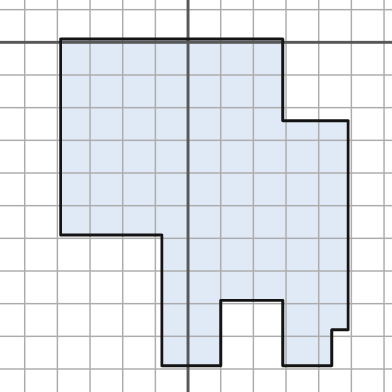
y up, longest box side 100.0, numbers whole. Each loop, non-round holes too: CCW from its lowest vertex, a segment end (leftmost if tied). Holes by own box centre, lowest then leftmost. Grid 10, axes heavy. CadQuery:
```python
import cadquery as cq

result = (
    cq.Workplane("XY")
    .moveTo(-8.0, -99.0)
    .lineTo(10.0, -99.0)
    .lineTo(10.0, -79.0)
    .lineTo(29.0, -79.0)
    .lineTo(29.0, -99.0)
    .lineTo(44.0, -99.0)
    .lineTo(44.0, -88.0)
    .lineTo(49.0, -88.0)
    .lineTo(49.0, -24.0)
    .lineTo(29.0, -24.0)
    .lineTo(29.0, 1.0)
    .lineTo(-39.0, 1.0)
    .lineTo(-39.0, -59.0)
    .lineTo(-8.0, -59.0)
    .close()
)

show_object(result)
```